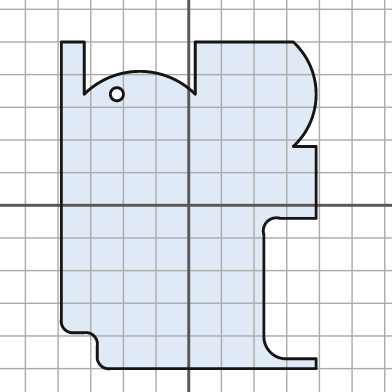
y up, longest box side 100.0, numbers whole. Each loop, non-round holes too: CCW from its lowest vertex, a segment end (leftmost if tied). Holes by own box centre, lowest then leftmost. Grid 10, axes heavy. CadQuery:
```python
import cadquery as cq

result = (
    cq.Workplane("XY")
    .moveTo(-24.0, -50.0)
    .lineTo(39.0, -50.0)
    .lineTo(39.0, -47.0)
    .lineTo(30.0, -47.0)
    .threePointArc((25.0, -45.0), (23.0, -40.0))
    .lineTo(23.0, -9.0)
    .threePointArc((24.0, -5.0), (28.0, -4.0))
    .lineTo(39.0, -4.0)
    .lineTo(39.0, 18.0)
    .lineTo(32.0, 18.0)
    .threePointArc((39.0, 34.0), (32.0, 50.0))
    .lineTo(2.0, 50.0)
    .lineTo(2.0, 34.0)
    .threePointArc((-15.0, 41.0), (-32.0, 34.0))
    .lineTo(-32.0, 50.0)
    .lineTo(-39.0, 50.0)
    .lineTo(-39.0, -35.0)
    .threePointArc((-38.0, -38.0), (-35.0, -39.0))
    .lineTo(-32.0, -39.0)
    .threePointArc((-29.0, -40.0), (-28.0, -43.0))
    .lineTo(-28.0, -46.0)
    .threePointArc((-27.0, -49.0), (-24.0, -50.0))
    .close()
    .moveTo(-22.0, 34.0)
    .circle(2.0)
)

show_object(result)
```